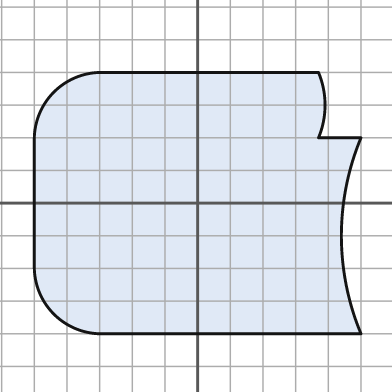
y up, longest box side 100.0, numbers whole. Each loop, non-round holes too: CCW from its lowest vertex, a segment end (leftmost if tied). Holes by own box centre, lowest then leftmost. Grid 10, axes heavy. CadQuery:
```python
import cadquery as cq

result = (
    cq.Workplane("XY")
    .moveTo(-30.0, -40.0)
    .lineTo(50.0, -40.0)
    .threePointArc((44.0, -10.0), (50.0, 20.0))
    .lineTo(37.0, 20.0)
    .threePointArc((39.0, 30.0), (37.0, 40.0))
    .lineTo(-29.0, 40.0)
    .threePointArc((-44.0, 34.0), (-50.0, 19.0))
    .lineTo(-50.0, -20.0)
    .threePointArc((-44.0, -34.0), (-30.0, -40.0))
    .close()
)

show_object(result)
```